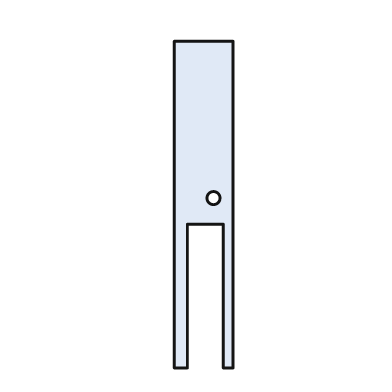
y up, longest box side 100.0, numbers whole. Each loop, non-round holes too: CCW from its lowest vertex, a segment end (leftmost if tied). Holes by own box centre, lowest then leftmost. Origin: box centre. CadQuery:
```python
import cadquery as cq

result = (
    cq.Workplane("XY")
    .moveTo(-9.0, -50.0)
    .lineTo(-5.0, -50.0)
    .lineTo(-5.0, -6.0)
    .lineTo(6.0, -6.0)
    .lineTo(6.0, -50.0)
    .lineTo(9.0, -50.0)
    .lineTo(9.0, 50.0)
    .lineTo(-9.0, 50.0)
    .close()
    .moveTo(3.0, 2.0)
    .circle(2.0)
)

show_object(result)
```